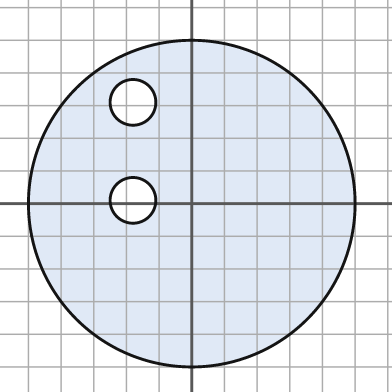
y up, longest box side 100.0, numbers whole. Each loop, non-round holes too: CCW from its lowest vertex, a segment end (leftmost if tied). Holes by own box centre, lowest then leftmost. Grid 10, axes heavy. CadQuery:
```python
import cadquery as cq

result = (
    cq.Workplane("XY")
    .moveTo(0.0, 0.0)
    .circle(50.0)
    .moveTo(-18.0, 1.0)
    .circle(7.0)
    .moveTo(-18.0, 31.0)
    .circle(7.0)
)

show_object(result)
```